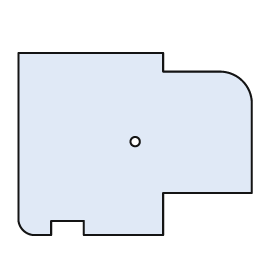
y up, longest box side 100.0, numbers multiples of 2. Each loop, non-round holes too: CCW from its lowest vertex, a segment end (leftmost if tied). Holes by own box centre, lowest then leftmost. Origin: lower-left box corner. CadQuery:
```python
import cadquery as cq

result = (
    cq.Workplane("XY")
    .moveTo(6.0, 0.0)
    .lineTo(14.0, 0.0)
    .lineTo(14.0, 6.0)
    .lineTo(28.0, 6.0)
    .lineTo(28.0, 0.0)
    .lineTo(62.0, 0.0)
    .lineTo(62.0, 18.0)
    .lineTo(100.0, 18.0)
    .lineTo(100.0, 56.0)
    .threePointArc((96.0, 66.0), (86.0, 70.0))
    .lineTo(62.0, 70.0)
    .lineTo(62.0, 78.0)
    .lineTo(0.0, 78.0)
    .lineTo(0.0, 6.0)
    .threePointArc((2.0, 2.0), (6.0, 0.0))
    .close()
    .moveTo(50.0, 40.0)
    .circle(2.0)
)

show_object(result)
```